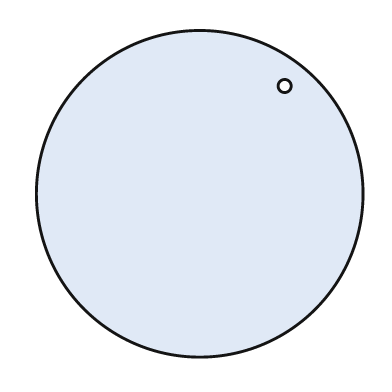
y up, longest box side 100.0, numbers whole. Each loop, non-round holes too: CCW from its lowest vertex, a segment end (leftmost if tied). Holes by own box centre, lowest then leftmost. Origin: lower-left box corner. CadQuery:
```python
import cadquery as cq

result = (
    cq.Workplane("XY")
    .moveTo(50.0, 50.0)
    .circle(50.0)
    .moveTo(76.0, 83.0)
    .circle(2.0)
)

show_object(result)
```